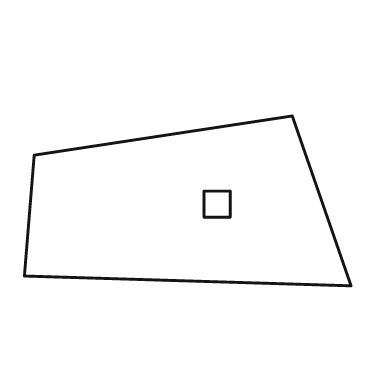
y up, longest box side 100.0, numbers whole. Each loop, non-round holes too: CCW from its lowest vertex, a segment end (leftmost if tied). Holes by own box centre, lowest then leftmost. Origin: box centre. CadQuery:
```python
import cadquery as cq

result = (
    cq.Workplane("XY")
    .moveTo(50.0, -26.0)
    .lineTo(32.0, 26.0)
    .lineTo(-47.0, 14.0)
    .lineTo(-50.0, -23.0)
    .close()
    .moveTo(5.0, -5.0)
    .lineTo(13.0, -5.0)
    .lineTo(13.0, 3.0)
    .lineTo(5.0, 3.0)
    .close()
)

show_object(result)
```